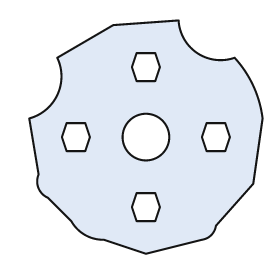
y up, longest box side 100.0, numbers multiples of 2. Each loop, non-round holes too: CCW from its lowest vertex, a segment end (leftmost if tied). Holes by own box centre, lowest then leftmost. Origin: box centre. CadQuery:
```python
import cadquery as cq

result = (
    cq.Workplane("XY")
    .moveTo(0.0, -50.0)
    .lineTo(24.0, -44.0)
    .threePointArc((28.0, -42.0), (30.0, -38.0))
    .lineTo(46.0, -20.0)
    .lineTo(50.0, 8.0)
    .threePointArc((46.0, 22.0), (38.0, 34.0))
    .threePointArc((22.0, 36.0), (14.0, 50.0))
    .lineTo(-14.0, 48.0)
    .lineTo(-38.0, 34.0)
    .threePointArc((-38.0, 18.0), (-50.0, 8.0))
    .lineTo(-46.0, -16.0)
    .threePointArc((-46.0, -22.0), (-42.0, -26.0))
    .lineTo(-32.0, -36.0)
    .threePointArc((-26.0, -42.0), (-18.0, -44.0))
    .close()
    .moveTo(-4.0, -36.0)
    .lineTo(4.0, -36.0)
    .lineTo(6.0, -30.0)
    .lineTo(4.0, -24.0)
    .lineTo(-4.0, -24.0)
    .lineTo(-6.0, -30.0)
    .close()
    .moveTo(-34.0, -6.0)
    .lineTo(-26.0, -6.0)
    .lineTo(-24.0, 0.0)
    .lineTo(-26.0, 6.0)
    .lineTo(-34.0, 6.0)
    .lineTo(-36.0, 0.0)
    .close()
    .moveTo(0.0, 0.0)
    .circle(10.0)
    .moveTo(26.0, -6.0)
    .lineTo(34.0, -6.0)
    .lineTo(36.0, 0.0)
    .lineTo(34.0, 6.0)
    .lineTo(26.0, 6.0)
    .lineTo(24.0, 0.0)
    .close()
    .moveTo(-4.0, 24.0)
    .lineTo(4.0, 24.0)
    .lineTo(6.0, 30.0)
    .lineTo(4.0, 36.0)
    .lineTo(-4.0, 36.0)
    .lineTo(-6.0, 30.0)
    .close()
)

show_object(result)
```